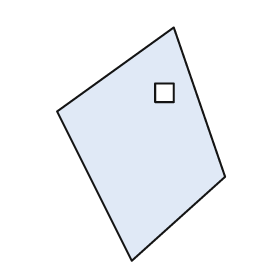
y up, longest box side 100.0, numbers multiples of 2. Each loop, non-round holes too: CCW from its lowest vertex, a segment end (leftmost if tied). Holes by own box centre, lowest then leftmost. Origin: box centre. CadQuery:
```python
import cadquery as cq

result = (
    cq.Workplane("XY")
    .moveTo(-4.0, -50.0)
    .lineTo(36.0, -14.0)
    .lineTo(14.0, 50.0)
    .lineTo(-36.0, 14.0)
    .close()
    .moveTo(6.0, 18.0)
    .lineTo(14.0, 18.0)
    .lineTo(14.0, 26.0)
    .lineTo(6.0, 26.0)
    .close()
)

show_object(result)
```